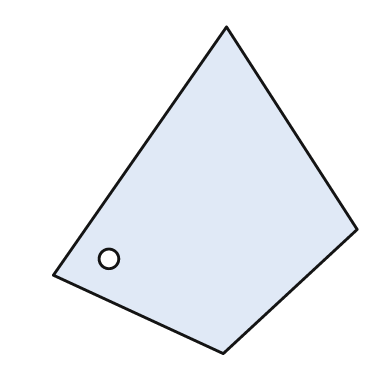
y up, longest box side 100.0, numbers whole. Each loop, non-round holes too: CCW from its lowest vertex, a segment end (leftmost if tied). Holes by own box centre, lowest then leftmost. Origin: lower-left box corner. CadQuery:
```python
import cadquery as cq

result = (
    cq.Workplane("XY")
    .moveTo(52.0, 0.0)
    .lineTo(93.0, 38.0)
    .lineTo(53.0, 100.0)
    .lineTo(0.0, 24.0)
    .close()
    .moveTo(17.0, 29.0)
    .circle(3.0)
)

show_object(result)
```